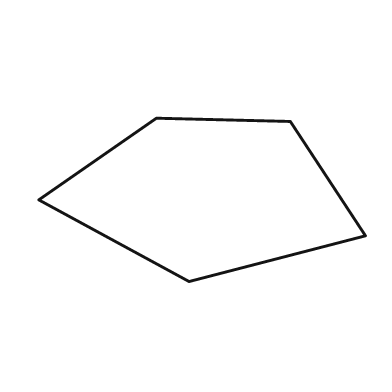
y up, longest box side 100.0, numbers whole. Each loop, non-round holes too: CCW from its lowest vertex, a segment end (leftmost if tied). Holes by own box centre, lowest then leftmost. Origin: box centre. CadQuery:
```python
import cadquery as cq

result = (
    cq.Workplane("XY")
    .moveTo(-4.0, -25.0)
    .lineTo(50.0, -11.0)
    .lineTo(27.0, 24.0)
    .lineTo(-14.0, 25.0)
    .lineTo(-50.0, 0.0)
    .close()
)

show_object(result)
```